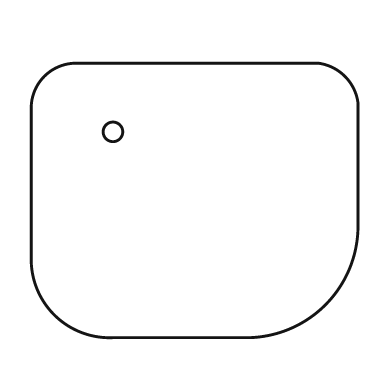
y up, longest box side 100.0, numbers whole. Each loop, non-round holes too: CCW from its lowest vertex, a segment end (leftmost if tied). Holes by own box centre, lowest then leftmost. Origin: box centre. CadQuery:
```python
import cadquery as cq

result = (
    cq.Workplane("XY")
    .moveTo(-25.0, -42.0)
    .lineTo(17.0, -42.0)
    .threePointArc((40.0, -32.0), (50.0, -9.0))
    .lineTo(50.0, 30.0)
    .threePointArc((46.0, 38.0), (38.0, 42.0))
    .lineTo(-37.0, 42.0)
    .threePointArc((-46.0, 38.0), (-50.0, 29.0))
    .lineTo(-50.0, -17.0)
    .threePointArc((-43.0, -35.0), (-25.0, -42.0))
    .close()
    .moveTo(-25.0, 21.0)
    .circle(3.0)
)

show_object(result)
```